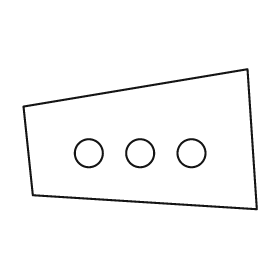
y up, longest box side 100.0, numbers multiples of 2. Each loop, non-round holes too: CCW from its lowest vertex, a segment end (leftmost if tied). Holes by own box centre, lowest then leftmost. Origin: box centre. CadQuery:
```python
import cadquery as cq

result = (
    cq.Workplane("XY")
    .moveTo(50.0, -30.0)
    .lineTo(46.0, 30.0)
    .lineTo(-50.0, 14.0)
    .lineTo(-46.0, -24.0)
    .close()
    .moveTo(-22.0, -6.0)
    .circle(6.0)
    .moveTo(0.0, -6.0)
    .circle(6.0)
    .moveTo(22.0, -6.0)
    .circle(6.0)
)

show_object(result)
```